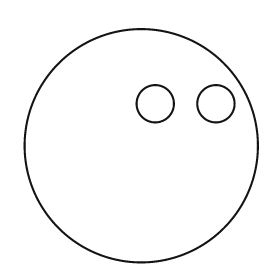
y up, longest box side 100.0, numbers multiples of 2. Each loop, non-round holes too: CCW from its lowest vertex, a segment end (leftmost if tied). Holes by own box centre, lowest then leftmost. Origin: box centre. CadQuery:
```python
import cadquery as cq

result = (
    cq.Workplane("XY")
    .moveTo(0.0, 0.0)
    .circle(50.0)
    .moveTo(6.0, 18.0)
    .circle(8.0)
    .moveTo(32.0, 18.0)
    .circle(8.0)
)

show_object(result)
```